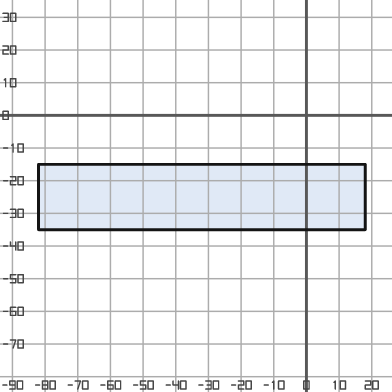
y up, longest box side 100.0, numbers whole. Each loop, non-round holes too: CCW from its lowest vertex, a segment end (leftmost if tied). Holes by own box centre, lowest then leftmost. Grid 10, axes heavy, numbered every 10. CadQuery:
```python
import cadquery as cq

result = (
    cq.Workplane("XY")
    .moveTo(-82.0, -35.0)
    .lineTo(18.0, -35.0)
    .lineTo(18.0, -15.0)
    .lineTo(-82.0, -15.0)
    .close()
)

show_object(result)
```